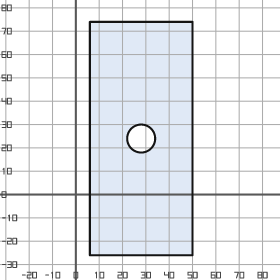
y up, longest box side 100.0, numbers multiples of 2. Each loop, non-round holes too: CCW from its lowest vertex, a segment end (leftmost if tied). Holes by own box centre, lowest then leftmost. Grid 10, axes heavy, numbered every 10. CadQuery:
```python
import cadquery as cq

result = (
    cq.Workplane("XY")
    .moveTo(6.0, -26.0)
    .lineTo(50.0, -26.0)
    .lineTo(50.0, 74.0)
    .lineTo(6.0, 74.0)
    .close()
    .moveTo(28.0, 24.0)
    .circle(6.0)
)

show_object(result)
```